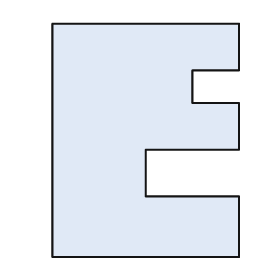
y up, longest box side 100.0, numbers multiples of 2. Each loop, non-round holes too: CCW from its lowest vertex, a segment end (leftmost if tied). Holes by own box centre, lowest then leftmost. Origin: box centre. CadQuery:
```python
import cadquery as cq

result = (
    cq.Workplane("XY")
    .moveTo(-40.0, -50.0)
    .lineTo(40.0, -50.0)
    .lineTo(40.0, -24.0)
    .lineTo(0.0, -24.0)
    .lineTo(0.0, -4.0)
    .lineTo(40.0, -4.0)
    .lineTo(40.0, 16.0)
    .lineTo(20.0, 16.0)
    .lineTo(20.0, 30.0)
    .lineTo(40.0, 30.0)
    .lineTo(40.0, 50.0)
    .lineTo(-40.0, 50.0)
    .close()
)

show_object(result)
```